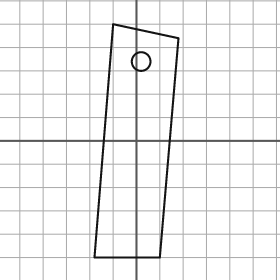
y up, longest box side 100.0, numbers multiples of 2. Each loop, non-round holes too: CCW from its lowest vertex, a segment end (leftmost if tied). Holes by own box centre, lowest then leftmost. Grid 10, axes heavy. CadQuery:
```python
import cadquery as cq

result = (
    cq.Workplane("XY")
    .moveTo(-18.0, -50.0)
    .lineTo(10.0, -50.0)
    .lineTo(18.0, 44.0)
    .lineTo(-10.0, 50.0)
    .close()
    .moveTo(2.0, 34.0)
    .circle(4.0)
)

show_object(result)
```